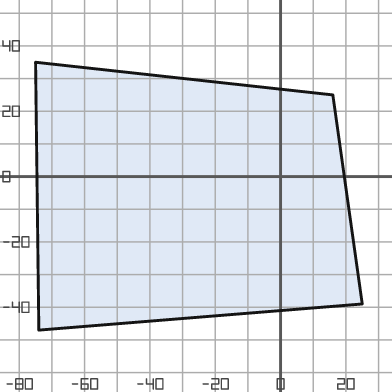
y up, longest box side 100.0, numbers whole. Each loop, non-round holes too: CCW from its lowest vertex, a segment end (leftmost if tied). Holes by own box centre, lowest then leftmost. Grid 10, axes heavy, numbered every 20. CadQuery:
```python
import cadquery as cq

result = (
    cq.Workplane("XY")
    .moveTo(-74.0, -47.0)
    .lineTo(25.0, -39.0)
    .lineTo(16.0, 25.0)
    .lineTo(-75.0, 35.0)
    .close()
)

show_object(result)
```